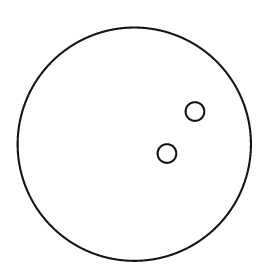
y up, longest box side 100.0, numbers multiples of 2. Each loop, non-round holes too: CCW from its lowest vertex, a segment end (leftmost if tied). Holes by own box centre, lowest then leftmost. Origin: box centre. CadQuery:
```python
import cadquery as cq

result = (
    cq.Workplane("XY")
    .moveTo(0.0, 0.0)
    .circle(50.0)
    .moveTo(14.0, -4.0)
    .circle(4.0)
    .moveTo(26.0, 14.0)
    .circle(4.0)
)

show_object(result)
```